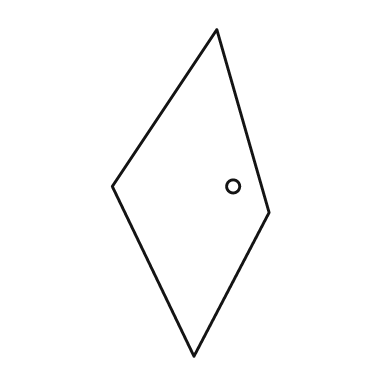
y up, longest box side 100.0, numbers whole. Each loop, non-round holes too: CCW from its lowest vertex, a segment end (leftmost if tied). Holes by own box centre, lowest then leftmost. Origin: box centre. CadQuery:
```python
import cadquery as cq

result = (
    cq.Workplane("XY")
    .moveTo(1.0, -50.0)
    .lineTo(24.0, -6.0)
    .lineTo(8.0, 50.0)
    .lineTo(-24.0, 2.0)
    .close()
    .moveTo(13.0, 2.0)
    .circle(2.0)
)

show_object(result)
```